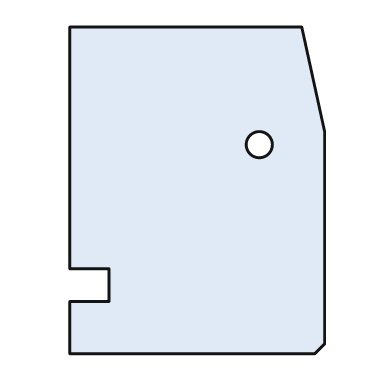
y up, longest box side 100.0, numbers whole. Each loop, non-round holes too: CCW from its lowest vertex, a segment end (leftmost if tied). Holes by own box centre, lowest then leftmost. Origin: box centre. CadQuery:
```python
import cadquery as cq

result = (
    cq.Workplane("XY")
    .moveTo(-39.0, -50.0)
    .lineTo(36.0, -50.0)
    .lineTo(39.0, -47.0)
    .lineTo(39.0, 18.0)
    .lineTo(32.0, 50.0)
    .lineTo(-39.0, 50.0)
    .lineTo(-39.0, -24.0)
    .lineTo(-27.0, -24.0)
    .lineTo(-27.0, -34.0)
    .lineTo(-39.0, -34.0)
    .close()
    .moveTo(19.0, 14.0)
    .circle(4.0)
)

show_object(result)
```